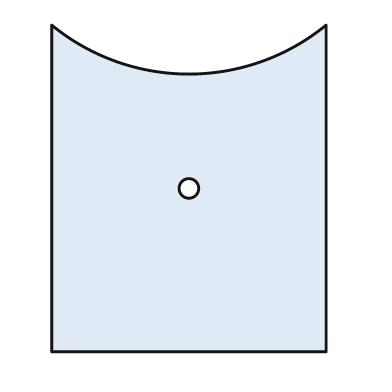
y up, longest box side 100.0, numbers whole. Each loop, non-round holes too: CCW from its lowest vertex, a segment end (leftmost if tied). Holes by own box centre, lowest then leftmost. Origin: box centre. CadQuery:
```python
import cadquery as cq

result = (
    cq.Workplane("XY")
    .moveTo(-42.0, -50.0)
    .lineTo(42.0, -50.0)
    .lineTo(42.0, 50.0)
    .threePointArc((0.0, 35.0), (-42.0, 50.0))
    .close()
    .moveTo(0.0, 0.0)
    .circle(3.0)
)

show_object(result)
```